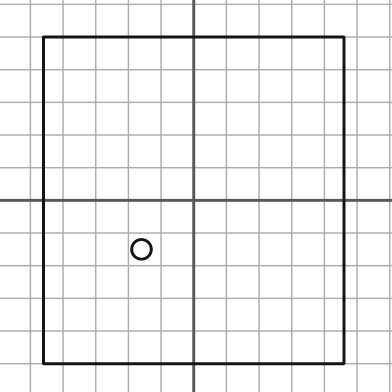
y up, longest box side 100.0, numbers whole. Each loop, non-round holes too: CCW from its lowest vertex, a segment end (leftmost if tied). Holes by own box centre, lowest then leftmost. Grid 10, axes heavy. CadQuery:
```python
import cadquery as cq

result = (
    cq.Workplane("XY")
    .moveTo(-46.0, -50.0)
    .lineTo(46.0, -50.0)
    .lineTo(46.0, 50.0)
    .lineTo(-46.0, 50.0)
    .close()
    .moveTo(-16.0, -15.0)
    .circle(3.0)
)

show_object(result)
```